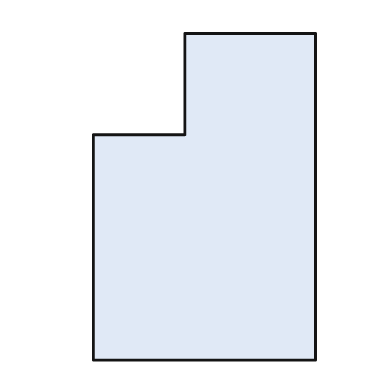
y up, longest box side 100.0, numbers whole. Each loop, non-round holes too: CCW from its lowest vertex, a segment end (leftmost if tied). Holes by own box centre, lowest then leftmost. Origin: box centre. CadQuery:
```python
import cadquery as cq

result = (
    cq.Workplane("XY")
    .moveTo(-34.0, -50.0)
    .lineTo(34.0, -50.0)
    .lineTo(34.0, 50.0)
    .lineTo(-6.0, 50.0)
    .lineTo(-6.0, 19.0)
    .lineTo(-34.0, 19.0)
    .close()
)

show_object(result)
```